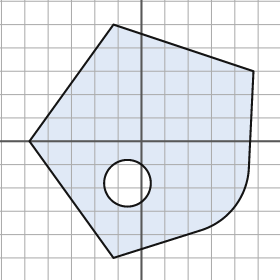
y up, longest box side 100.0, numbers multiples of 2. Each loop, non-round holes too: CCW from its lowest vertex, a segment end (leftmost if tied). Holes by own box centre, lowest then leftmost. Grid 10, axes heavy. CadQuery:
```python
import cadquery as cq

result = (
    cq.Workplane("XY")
    .moveTo(-12.0, -50.0)
    .lineTo(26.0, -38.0)
    .threePointArc((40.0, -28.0), (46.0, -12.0))
    .lineTo(48.0, 30.0)
    .lineTo(-12.0, 50.0)
    .lineTo(-48.0, 0.0)
    .close()
    .moveTo(-6.0, -18.0)
    .circle(10.0)
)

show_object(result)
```